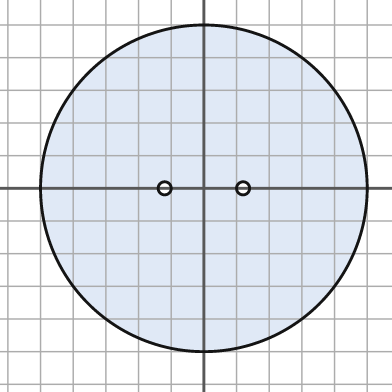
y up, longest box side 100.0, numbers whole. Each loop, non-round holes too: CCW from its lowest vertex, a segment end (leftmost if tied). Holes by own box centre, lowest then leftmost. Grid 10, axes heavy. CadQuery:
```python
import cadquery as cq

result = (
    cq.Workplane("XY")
    .moveTo(0.0, 0.0)
    .circle(50.0)
    .moveTo(-12.0, 0.0)
    .circle(2.0)
    .moveTo(12.0, 0.0)
    .circle(2.0)
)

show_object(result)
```